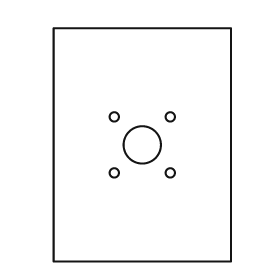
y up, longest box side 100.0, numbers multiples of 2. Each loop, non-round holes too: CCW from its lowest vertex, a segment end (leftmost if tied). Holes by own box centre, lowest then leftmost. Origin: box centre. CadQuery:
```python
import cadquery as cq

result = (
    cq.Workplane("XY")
    .moveTo(-38.0, -50.0)
    .lineTo(38.0, -50.0)
    .lineTo(38.0, 50.0)
    .lineTo(-38.0, 50.0)
    .close()
    .moveTo(-12.0, -12.0)
    .circle(2.0)
    .moveTo(12.0, -12.0)
    .circle(2.0)
    .moveTo(0.0, 0.0)
    .circle(8.0)
    .moveTo(-12.0, 12.0)
    .circle(2.0)
    .moveTo(12.0, 12.0)
    .circle(2.0)
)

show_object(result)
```